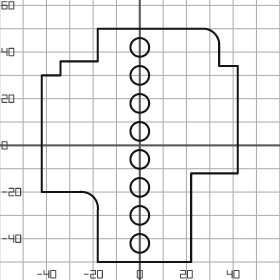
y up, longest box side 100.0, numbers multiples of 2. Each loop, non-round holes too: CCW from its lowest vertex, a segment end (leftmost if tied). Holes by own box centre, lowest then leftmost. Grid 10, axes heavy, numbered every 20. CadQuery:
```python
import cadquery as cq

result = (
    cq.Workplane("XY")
    .moveTo(-18.0, -50.0)
    .lineTo(22.0, -50.0)
    .lineTo(22.0, -12.0)
    .lineTo(42.0, -12.0)
    .lineTo(42.0, 34.0)
    .lineTo(34.0, 34.0)
    .lineTo(34.0, 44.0)
    .threePointArc((32.0, 48.0), (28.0, 50.0))
    .lineTo(-18.0, 50.0)
    .lineTo(-18.0, 36.0)
    .lineTo(-34.0, 36.0)
    .lineTo(-34.0, 30.0)
    .lineTo(-42.0, 30.0)
    .lineTo(-42.0, -20.0)
    .lineTo(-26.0, -20.0)
    .threePointArc((-20.0, -22.0), (-18.0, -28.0))
    .close()
    .moveTo(0.0, -42.0)
    .circle(4.0)
    .moveTo(0.0, -30.0)
    .circle(4.0)
    .moveTo(0.0, -18.0)
    .circle(4.0)
    .moveTo(0.0, -6.0)
    .circle(4.0)
    .moveTo(0.0, 6.0)
    .circle(4.0)
    .moveTo(0.0, 18.0)
    .circle(4.0)
    .moveTo(0.0, 30.0)
    .circle(4.0)
    .moveTo(0.0, 42.0)
    .circle(4.0)
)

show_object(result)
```